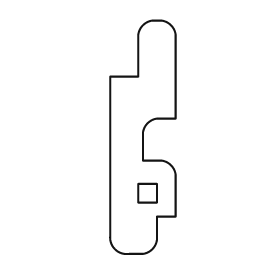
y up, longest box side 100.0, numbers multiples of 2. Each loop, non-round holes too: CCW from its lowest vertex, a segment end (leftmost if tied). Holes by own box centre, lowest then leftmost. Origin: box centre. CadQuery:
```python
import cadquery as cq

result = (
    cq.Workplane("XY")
    .moveTo(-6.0, -50.0)
    .lineTo(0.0, -50.0)
    .threePointArc((4.0, -48.0), (6.0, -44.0))
    .lineTo(6.0, -34.0)
    .lineTo(14.0, -34.0)
    .lineTo(14.0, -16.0)
    .threePointArc((12.0, -12.0), (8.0, -10.0))
    .lineTo(0.0, -10.0)
    .lineTo(0.0, 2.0)
    .threePointArc((2.0, 6.0), (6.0, 8.0))
    .lineTo(14.0, 8.0)
    .lineTo(14.0, 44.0)
    .threePointArc((12.0, 48.0), (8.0, 50.0))
    .lineTo(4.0, 50.0)
    .threePointArc((0.0, 48.0), (-2.0, 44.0))
    .lineTo(-2.0, 26.0)
    .lineTo(-14.0, 26.0)
    .lineTo(-14.0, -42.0)
    .threePointArc((-12.0, -48.0), (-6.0, -50.0))
    .close()
    .moveTo(-2.0, -28.0)
    .lineTo(6.0, -28.0)
    .lineTo(6.0, -20.0)
    .lineTo(-2.0, -20.0)
    .close()
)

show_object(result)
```